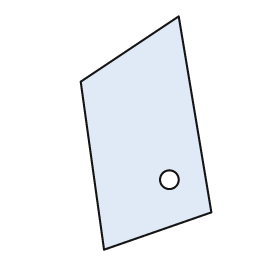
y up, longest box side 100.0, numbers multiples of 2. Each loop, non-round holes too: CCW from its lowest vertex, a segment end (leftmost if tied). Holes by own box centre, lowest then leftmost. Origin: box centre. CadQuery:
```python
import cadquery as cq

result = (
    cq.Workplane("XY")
    .moveTo(-18.0, -50.0)
    .lineTo(28.0, -34.0)
    .lineTo(14.0, 50.0)
    .lineTo(-28.0, 22.0)
    .close()
    .moveTo(10.0, -20.0)
    .circle(4.0)
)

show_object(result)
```